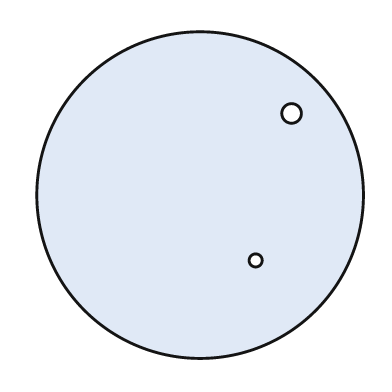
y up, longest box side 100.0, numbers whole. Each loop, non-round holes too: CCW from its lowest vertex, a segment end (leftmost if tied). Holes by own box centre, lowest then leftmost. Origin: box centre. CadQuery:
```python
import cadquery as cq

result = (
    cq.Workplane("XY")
    .moveTo(0.0, 0.0)
    .circle(50.0)
    .moveTo(17.0, -20.0)
    .circle(2.0)
    .moveTo(28.0, 25.0)
    .circle(3.0)
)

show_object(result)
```